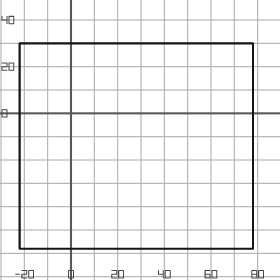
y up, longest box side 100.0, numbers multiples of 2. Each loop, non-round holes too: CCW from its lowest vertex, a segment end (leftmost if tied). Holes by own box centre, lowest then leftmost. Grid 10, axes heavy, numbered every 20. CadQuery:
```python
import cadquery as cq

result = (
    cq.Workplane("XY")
    .moveTo(-22.0, -58.0)
    .lineTo(78.0, -58.0)
    .lineTo(78.0, 30.0)
    .lineTo(-22.0, 30.0)
    .close()
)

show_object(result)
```